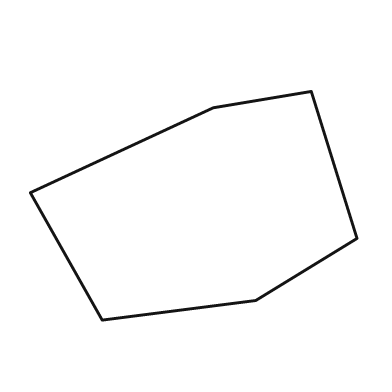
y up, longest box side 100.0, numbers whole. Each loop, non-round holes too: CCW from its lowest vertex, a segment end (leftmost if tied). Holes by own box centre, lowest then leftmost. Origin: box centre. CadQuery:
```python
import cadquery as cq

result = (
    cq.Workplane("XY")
    .moveTo(-28.0, -35.0)
    .lineTo(19.0, -29.0)
    .lineTo(50.0, -10.0)
    .lineTo(36.0, 35.0)
    .lineTo(6.0, 30.0)
    .lineTo(-50.0, 4.0)
    .close()
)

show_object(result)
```